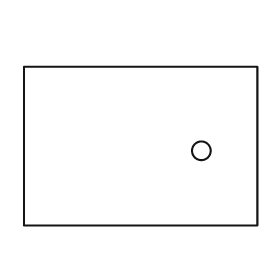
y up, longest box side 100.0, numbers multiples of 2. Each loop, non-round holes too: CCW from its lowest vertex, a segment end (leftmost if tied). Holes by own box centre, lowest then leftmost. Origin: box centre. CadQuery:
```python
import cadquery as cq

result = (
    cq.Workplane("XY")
    .moveTo(-50.0, -34.0)
    .lineTo(50.0, -34.0)
    .lineTo(50.0, 34.0)
    .lineTo(-50.0, 34.0)
    .close()
    .moveTo(26.0, -2.0)
    .circle(4.0)
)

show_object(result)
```